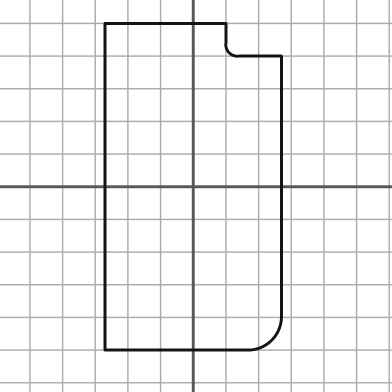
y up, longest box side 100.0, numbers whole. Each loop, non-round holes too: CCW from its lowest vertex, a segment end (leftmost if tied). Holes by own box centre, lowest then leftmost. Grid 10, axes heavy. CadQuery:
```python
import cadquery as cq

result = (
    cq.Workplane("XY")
    .moveTo(-27.0, -50.0)
    .lineTo(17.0, -50.0)
    .threePointArc((24.0, -47.0), (27.0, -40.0))
    .lineTo(27.0, 40.0)
    .lineTo(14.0, 40.0)
    .threePointArc((11.0, 41.0), (10.0, 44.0))
    .lineTo(10.0, 50.0)
    .lineTo(-27.0, 50.0)
    .close()
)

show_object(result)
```